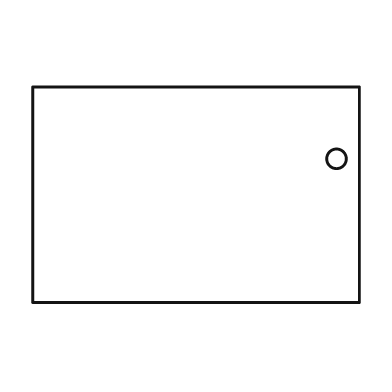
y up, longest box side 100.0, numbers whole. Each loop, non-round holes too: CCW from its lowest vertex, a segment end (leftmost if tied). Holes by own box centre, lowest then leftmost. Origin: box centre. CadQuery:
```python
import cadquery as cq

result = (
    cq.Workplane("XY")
    .moveTo(-50.0, -33.0)
    .lineTo(50.0, -33.0)
    .lineTo(50.0, 33.0)
    .lineTo(-50.0, 33.0)
    .close()
    .moveTo(43.0, 11.0)
    .circle(3.0)
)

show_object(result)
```